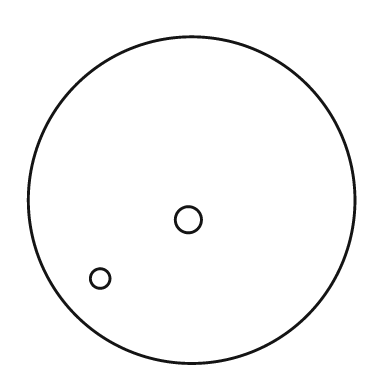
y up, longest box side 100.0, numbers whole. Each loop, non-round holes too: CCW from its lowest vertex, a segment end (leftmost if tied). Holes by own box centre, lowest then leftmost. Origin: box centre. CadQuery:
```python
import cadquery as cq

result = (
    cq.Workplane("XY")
    .moveTo(0.0, 0.0)
    .circle(50.0)
    .moveTo(-28.0, -24.0)
    .circle(3.0)
    .moveTo(-1.0, -6.0)
    .circle(4.0)
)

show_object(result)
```